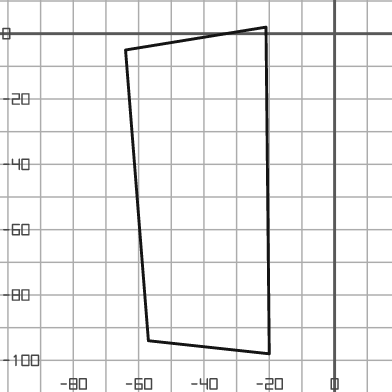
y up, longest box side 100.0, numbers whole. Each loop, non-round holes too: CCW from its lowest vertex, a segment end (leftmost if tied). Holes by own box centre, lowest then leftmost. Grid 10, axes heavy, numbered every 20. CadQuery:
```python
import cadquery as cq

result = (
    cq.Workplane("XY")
    .moveTo(-20.0, -98.0)
    .lineTo(-21.0, 2.0)
    .lineTo(-64.0, -5.0)
    .lineTo(-57.0, -94.0)
    .close()
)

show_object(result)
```